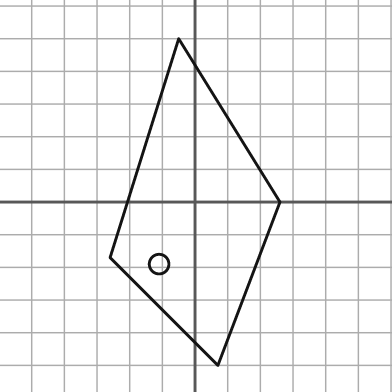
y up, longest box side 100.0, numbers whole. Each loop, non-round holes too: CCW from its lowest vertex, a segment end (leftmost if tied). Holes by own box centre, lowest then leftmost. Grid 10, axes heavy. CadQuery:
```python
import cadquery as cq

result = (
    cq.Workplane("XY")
    .moveTo(7.0, -50.0)
    .lineTo(26.0, 0.0)
    .lineTo(-5.0, 50.0)
    .lineTo(-26.0, -17.0)
    .close()
    .moveTo(-11.0, -19.0)
    .circle(3.0)
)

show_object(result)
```